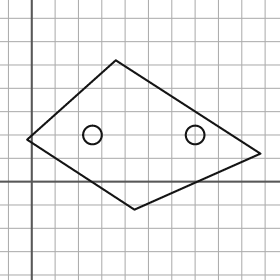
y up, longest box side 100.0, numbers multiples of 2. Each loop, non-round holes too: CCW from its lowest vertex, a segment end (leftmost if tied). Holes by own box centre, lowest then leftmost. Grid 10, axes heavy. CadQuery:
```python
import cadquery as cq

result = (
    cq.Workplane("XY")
    .moveTo(44.0, -12.0)
    .lineTo(98.0, 12.0)
    .lineTo(36.0, 52.0)
    .lineTo(-2.0, 18.0)
    .close()
    .moveTo(26.0, 20.0)
    .circle(4.0)
    .moveTo(70.0, 20.0)
    .circle(4.0)
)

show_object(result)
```